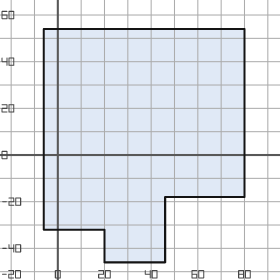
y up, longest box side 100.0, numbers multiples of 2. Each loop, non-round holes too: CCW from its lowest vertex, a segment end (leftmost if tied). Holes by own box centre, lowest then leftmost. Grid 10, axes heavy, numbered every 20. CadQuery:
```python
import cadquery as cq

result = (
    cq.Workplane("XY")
    .moveTo(20.0, -46.0)
    .lineTo(46.0, -46.0)
    .lineTo(46.0, -18.0)
    .lineTo(80.0, -18.0)
    .lineTo(80.0, 54.0)
    .lineTo(-6.0, 54.0)
    .lineTo(-6.0, -32.0)
    .lineTo(20.0, -32.0)
    .close()
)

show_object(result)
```